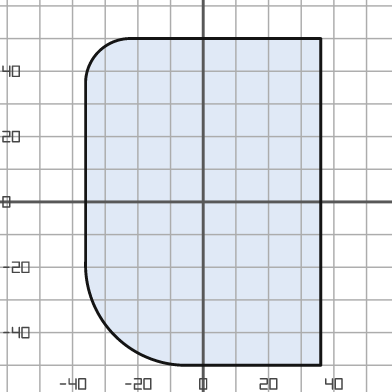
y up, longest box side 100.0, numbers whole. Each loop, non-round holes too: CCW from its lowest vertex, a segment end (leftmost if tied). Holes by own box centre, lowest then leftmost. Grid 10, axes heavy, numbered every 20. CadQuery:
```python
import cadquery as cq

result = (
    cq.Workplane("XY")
    .moveTo(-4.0, -50.0)
    .lineTo(36.0, -50.0)
    .lineTo(36.0, 50.0)
    .lineTo(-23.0, 50.0)
    .threePointArc((-32.0, 46.0), (-36.0, 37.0))
    .lineTo(-36.0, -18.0)
    .threePointArc((-27.0, -41.0), (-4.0, -50.0))
    .close()
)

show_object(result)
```